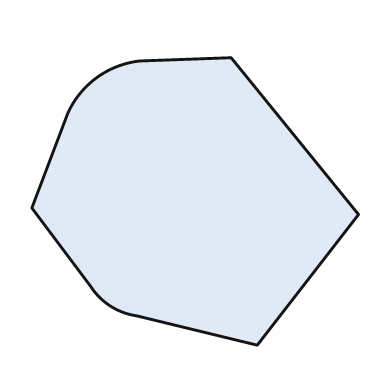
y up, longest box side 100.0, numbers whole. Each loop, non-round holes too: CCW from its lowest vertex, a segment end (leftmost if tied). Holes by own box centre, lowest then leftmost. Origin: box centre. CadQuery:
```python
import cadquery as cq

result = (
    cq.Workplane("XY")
    .moveTo(19.0, -44.0)
    .lineTo(50.0, -4.0)
    .lineTo(11.0, 44.0)
    .lineTo(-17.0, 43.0)
    .threePointArc((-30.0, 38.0), (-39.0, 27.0))
    .lineTo(-50.0, -2.0)
    .lineTo(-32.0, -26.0)
    .threePointArc((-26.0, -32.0), (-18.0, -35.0))
    .close()
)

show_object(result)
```